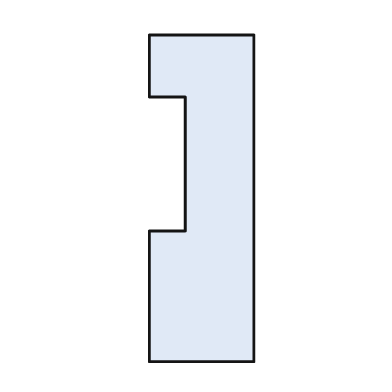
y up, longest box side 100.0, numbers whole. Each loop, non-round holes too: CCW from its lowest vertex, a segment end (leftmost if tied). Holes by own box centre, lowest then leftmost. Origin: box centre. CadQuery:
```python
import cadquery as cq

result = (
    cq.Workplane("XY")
    .moveTo(-16.0, -50.0)
    .lineTo(16.0, -50.0)
    .lineTo(16.0, 50.0)
    .lineTo(-16.0, 50.0)
    .lineTo(-16.0, 31.0)
    .lineTo(-5.0, 31.0)
    .lineTo(-5.0, -10.0)
    .lineTo(-16.0, -10.0)
    .close()
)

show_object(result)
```